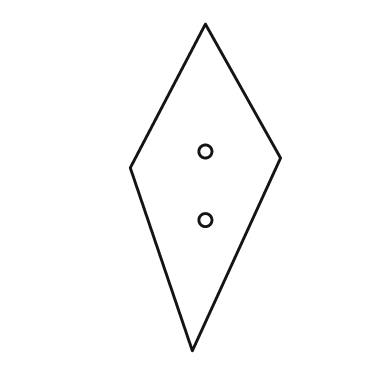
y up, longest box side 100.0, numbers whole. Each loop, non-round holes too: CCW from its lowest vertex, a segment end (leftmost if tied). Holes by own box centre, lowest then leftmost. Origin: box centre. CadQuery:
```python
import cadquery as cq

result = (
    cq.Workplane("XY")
    .moveTo(-4.0, -50.0)
    .lineTo(23.0, 9.0)
    .lineTo(0.0, 50.0)
    .lineTo(-23.0, 6.0)
    .close()
    .moveTo(0.0, -10.0)
    .circle(2.0)
    .moveTo(0.0, 11.0)
    .circle(2.0)
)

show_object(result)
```